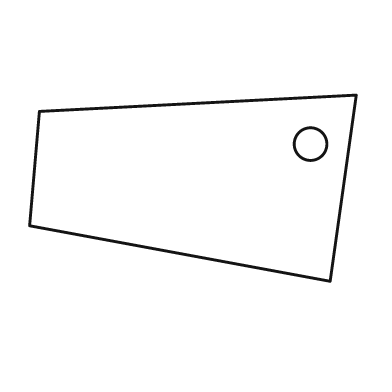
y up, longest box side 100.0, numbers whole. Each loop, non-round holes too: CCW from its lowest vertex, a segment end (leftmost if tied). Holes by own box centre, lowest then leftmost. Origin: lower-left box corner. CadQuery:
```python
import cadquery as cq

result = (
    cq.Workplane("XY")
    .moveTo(92.0, 0.0)
    .lineTo(100.0, 57.0)
    .lineTo(3.0, 52.0)
    .lineTo(0.0, 17.0)
    .close()
    .moveTo(86.0, 42.0)
    .circle(5.0)
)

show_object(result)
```